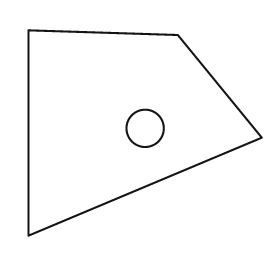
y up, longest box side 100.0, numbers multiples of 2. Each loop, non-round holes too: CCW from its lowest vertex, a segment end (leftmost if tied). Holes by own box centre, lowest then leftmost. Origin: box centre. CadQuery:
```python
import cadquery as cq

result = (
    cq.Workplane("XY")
    .moveTo(-50.0, -44.0)
    .lineTo(50.0, -2.0)
    .lineTo(14.0, 42.0)
    .lineTo(-50.0, 44.0)
    .close()
    .moveTo(0.0, 2.0)
    .circle(8.0)
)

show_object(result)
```